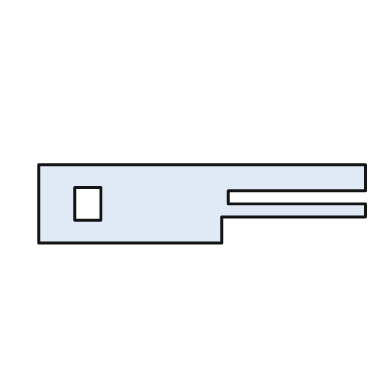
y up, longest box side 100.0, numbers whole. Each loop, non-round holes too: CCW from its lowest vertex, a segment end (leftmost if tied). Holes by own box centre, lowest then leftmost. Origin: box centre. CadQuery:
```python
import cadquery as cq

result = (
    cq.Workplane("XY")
    .moveTo(-50.0, -12.0)
    .lineTo(6.0, -12.0)
    .lineTo(6.0, -4.0)
    .lineTo(50.0, -4.0)
    .lineTo(50.0, 0.0)
    .lineTo(8.0, 0.0)
    .lineTo(8.0, 4.0)
    .lineTo(50.0, 4.0)
    .lineTo(50.0, 12.0)
    .lineTo(-50.0, 12.0)
    .close()
    .moveTo(-39.0, -5.0)
    .lineTo(-31.0, -5.0)
    .lineTo(-31.0, 5.0)
    .lineTo(-39.0, 5.0)
    .close()
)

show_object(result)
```